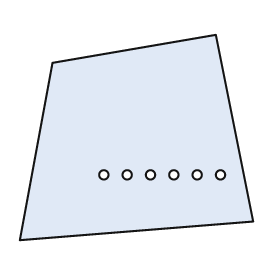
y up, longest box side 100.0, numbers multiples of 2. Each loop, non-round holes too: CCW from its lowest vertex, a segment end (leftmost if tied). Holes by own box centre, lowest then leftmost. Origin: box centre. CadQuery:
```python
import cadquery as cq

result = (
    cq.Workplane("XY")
    .moveTo(-50.0, -44.0)
    .lineTo(50.0, -36.0)
    .lineTo(34.0, 44.0)
    .lineTo(-36.0, 32.0)
    .close()
    .moveTo(-14.0, -16.0)
    .circle(2.0)
    .moveTo(-4.0, -16.0)
    .circle(2.0)
    .moveTo(6.0, -16.0)
    .circle(2.0)
    .moveTo(16.0, -16.0)
    .circle(2.0)
    .moveTo(26.0, -16.0)
    .circle(2.0)
    .moveTo(36.0, -16.0)
    .circle(2.0)
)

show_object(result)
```